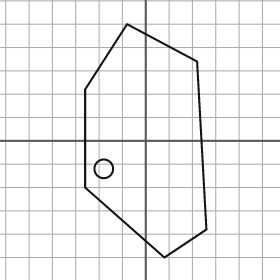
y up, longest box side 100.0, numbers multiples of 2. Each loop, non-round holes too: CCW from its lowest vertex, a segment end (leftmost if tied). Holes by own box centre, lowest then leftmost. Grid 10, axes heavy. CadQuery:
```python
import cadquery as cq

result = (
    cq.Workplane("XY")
    .moveTo(8.0, -50.0)
    .lineTo(26.0, -38.0)
    .lineTo(22.0, 34.0)
    .lineTo(-8.0, 50.0)
    .lineTo(-26.0, 22.0)
    .lineTo(-26.0, -20.0)
    .close()
    .moveTo(-18.0, -12.0)
    .circle(4.0)
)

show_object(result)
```